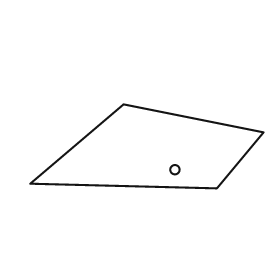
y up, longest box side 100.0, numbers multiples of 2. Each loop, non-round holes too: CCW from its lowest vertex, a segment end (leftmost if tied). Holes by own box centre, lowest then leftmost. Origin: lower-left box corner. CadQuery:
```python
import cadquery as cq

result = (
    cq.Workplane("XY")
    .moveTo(80.0, 0.0)
    .lineTo(100.0, 24.0)
    .lineTo(40.0, 36.0)
    .lineTo(0.0, 2.0)
    .close()
    .moveTo(62.0, 8.0)
    .circle(2.0)
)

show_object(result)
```